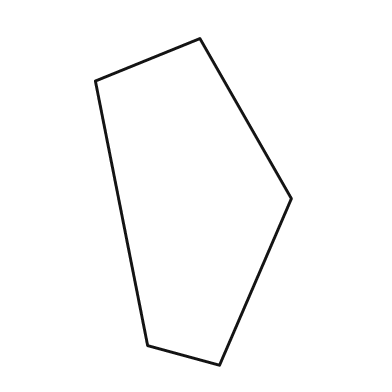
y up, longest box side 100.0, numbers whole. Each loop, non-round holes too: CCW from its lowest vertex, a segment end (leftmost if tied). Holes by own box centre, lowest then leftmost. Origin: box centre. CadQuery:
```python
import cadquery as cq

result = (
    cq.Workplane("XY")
    .moveTo(8.0, -50.0)
    .lineTo(30.0, 1.0)
    .lineTo(2.0, 50.0)
    .lineTo(-30.0, 37.0)
    .lineTo(-14.0, -44.0)
    .close()
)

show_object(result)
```